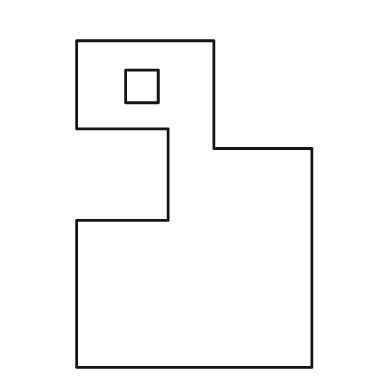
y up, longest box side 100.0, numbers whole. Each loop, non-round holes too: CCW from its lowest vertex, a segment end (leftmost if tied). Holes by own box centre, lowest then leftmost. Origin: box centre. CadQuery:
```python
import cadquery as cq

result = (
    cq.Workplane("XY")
    .moveTo(-36.0, -50.0)
    .lineTo(36.0, -50.0)
    .lineTo(36.0, 17.0)
    .lineTo(6.0, 17.0)
    .lineTo(6.0, 50.0)
    .lineTo(-36.0, 50.0)
    .lineTo(-36.0, 23.0)
    .lineTo(-8.0, 23.0)
    .lineTo(-8.0, -5.0)
    .lineTo(-36.0, -5.0)
    .close()
    .moveTo(-21.0, 31.0)
    .lineTo(-11.0, 31.0)
    .lineTo(-11.0, 41.0)
    .lineTo(-21.0, 41.0)
    .close()
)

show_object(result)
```